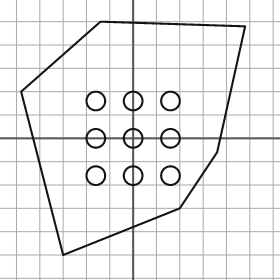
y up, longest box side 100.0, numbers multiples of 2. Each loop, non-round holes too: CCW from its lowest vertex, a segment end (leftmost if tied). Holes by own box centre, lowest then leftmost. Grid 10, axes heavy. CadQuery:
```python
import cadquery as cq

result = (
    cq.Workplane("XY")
    .moveTo(-30.0, -50.0)
    .lineTo(20.0, -30.0)
    .lineTo(36.0, -6.0)
    .lineTo(48.0, 48.0)
    .lineTo(-14.0, 50.0)
    .lineTo(-48.0, 20.0)
    .close()
    .moveTo(-16.0, -16.0)
    .circle(4.0)
    .moveTo(0.0, -16.0)
    .circle(4.0)
    .moveTo(16.0, -16.0)
    .circle(4.0)
    .moveTo(-16.0, 0.0)
    .circle(4.0)
    .moveTo(0.0, 0.0)
    .circle(4.0)
    .moveTo(16.0, 0.0)
    .circle(4.0)
    .moveTo(-16.0, 16.0)
    .circle(4.0)
    .moveTo(0.0, 16.0)
    .circle(4.0)
    .moveTo(16.0, 16.0)
    .circle(4.0)
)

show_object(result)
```